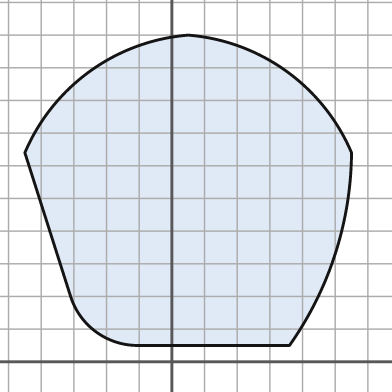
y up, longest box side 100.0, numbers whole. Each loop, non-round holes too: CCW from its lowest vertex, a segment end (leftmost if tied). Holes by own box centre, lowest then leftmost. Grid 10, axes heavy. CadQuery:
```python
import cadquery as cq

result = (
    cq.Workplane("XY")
    .moveTo(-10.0, 5.0)
    .lineTo(36.0, 5.0)
    .threePointArc((50.0, 33.0), (55.0, 64.0))
    .threePointArc((35.0, 89.0), (5.0, 100.0))
    .threePointArc((-25.0, 89.0), (-45.0, 64.0))
    .lineTo(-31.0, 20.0)
    .threePointArc((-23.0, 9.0), (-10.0, 5.0))
    .close()
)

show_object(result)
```